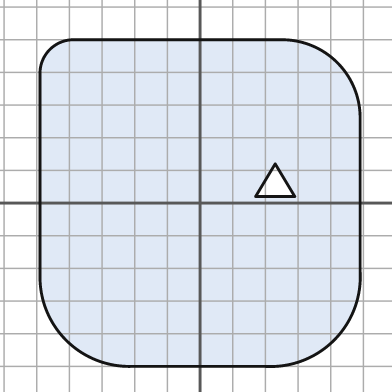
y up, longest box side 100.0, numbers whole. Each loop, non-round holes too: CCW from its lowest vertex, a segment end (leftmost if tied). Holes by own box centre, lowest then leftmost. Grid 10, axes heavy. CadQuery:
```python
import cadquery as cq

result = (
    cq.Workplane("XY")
    .moveTo(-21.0, -50.0)
    .lineTo(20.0, -50.0)
    .threePointArc((41.0, -42.0), (49.0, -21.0))
    .lineTo(49.0, 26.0)
    .threePointArc((42.0, 43.0), (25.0, 50.0))
    .lineTo(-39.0, 50.0)
    .threePointArc((-46.0, 47.0), (-49.0, 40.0))
    .lineTo(-49.0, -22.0)
    .threePointArc((-41.0, -42.0), (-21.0, -50.0))
    .close()
    .moveTo(17.0, 2.0)
    .lineTo(29.0, 2.0)
    .lineTo(23.0, 12.0)
    .close()
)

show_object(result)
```